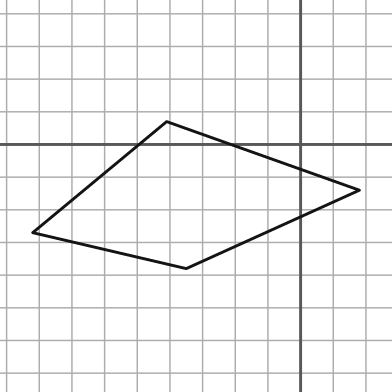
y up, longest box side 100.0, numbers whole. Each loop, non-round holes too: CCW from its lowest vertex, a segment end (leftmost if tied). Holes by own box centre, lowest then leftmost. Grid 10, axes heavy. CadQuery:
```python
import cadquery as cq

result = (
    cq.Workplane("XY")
    .moveTo(-35.0, -38.0)
    .lineTo(18.0, -14.0)
    .lineTo(-41.0, 7.0)
    .lineTo(-82.0, -27.0)
    .close()
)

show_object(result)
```